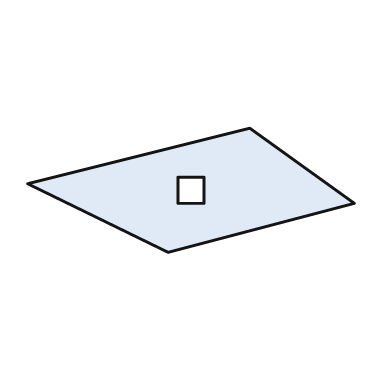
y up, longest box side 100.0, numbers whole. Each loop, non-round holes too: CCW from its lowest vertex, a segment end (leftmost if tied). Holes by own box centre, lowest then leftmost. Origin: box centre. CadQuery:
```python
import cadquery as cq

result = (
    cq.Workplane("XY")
    .moveTo(-7.0, -19.0)
    .lineTo(50.0, -4.0)
    .lineTo(18.0, 19.0)
    .lineTo(-50.0, 2.0)
    .close()
    .moveTo(-4.0, -4.0)
    .lineTo(4.0, -4.0)
    .lineTo(4.0, 4.0)
    .lineTo(-4.0, 4.0)
    .close()
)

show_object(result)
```